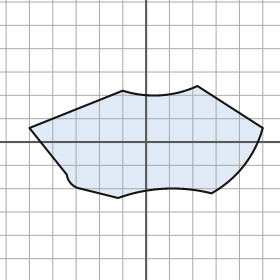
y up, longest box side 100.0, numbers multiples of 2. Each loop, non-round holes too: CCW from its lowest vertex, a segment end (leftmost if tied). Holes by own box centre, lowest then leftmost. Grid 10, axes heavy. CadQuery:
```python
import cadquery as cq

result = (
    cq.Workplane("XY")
    .moveTo(-12.0, -24.0)
    .threePointArc((8.0, -20.0), (28.0, -22.0))
    .threePointArc((42.0, -10.0), (50.0, 6.0))
    .lineTo(22.0, 24.0)
    .threePointArc((6.0, 20.0), (-10.0, 22.0))
    .lineTo(-50.0, 6.0)
    .lineTo(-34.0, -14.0)
    .threePointArc((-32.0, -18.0), (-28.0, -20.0))
    .close()
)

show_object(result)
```